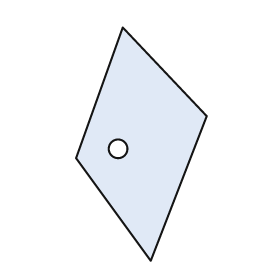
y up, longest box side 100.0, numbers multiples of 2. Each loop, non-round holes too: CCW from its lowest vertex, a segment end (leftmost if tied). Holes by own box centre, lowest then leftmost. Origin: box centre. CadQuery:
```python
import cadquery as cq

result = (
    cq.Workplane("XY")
    .moveTo(4.0, -50.0)
    .lineTo(28.0, 12.0)
    .lineTo(-8.0, 50.0)
    .lineTo(-28.0, -6.0)
    .close()
    .moveTo(-10.0, -2.0)
    .circle(4.0)
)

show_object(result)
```